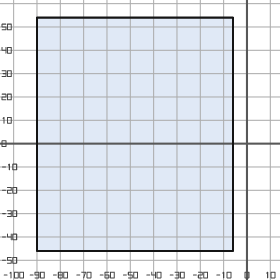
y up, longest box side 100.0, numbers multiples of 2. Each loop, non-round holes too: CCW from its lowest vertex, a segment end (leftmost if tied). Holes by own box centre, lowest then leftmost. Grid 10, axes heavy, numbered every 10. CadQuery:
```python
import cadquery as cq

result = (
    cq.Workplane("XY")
    .moveTo(-90.0, -46.0)
    .lineTo(-6.0, -46.0)
    .lineTo(-6.0, 54.0)
    .lineTo(-90.0, 54.0)
    .close()
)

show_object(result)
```